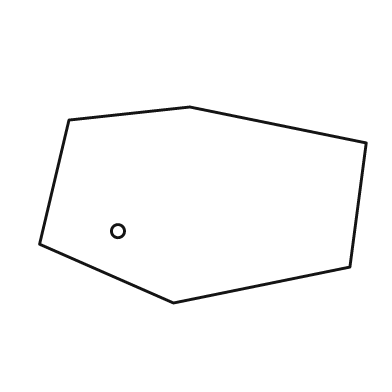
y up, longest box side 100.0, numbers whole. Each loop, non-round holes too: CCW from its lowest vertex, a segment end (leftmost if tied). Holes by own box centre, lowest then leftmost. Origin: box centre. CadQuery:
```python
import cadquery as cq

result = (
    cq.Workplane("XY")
    .moveTo(-9.0, -30.0)
    .lineTo(45.0, -19.0)
    .lineTo(50.0, 19.0)
    .lineTo(-4.0, 30.0)
    .lineTo(-41.0, 26.0)
    .lineTo(-50.0, -12.0)
    .close()
    .moveTo(-26.0, -8.0)
    .circle(2.0)
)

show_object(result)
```